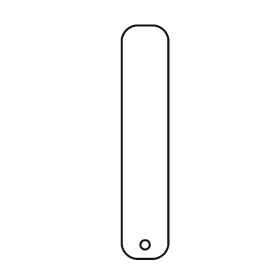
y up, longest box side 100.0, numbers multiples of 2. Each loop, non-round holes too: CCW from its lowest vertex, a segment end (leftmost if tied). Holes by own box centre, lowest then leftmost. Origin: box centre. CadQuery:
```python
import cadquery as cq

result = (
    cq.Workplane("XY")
    .moveTo(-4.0, -50.0)
    .lineTo(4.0, -50.0)
    .threePointArc((8.0, -48.0), (10.0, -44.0))
    .lineTo(10.0, 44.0)
    .threePointArc((8.0, 48.0), (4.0, 50.0))
    .lineTo(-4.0, 50.0)
    .threePointArc((-8.0, 48.0), (-10.0, 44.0))
    .lineTo(-10.0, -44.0)
    .threePointArc((-8.0, -48.0), (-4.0, -50.0))
    .close()
    .moveTo(0.0, -44.0)
    .circle(2.0)
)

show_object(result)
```